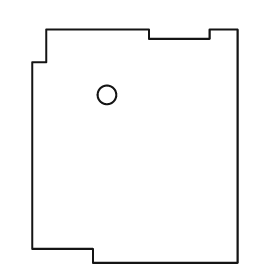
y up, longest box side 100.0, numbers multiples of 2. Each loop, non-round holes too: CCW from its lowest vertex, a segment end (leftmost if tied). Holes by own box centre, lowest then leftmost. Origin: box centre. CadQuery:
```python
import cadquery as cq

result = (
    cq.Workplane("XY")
    .moveTo(-18.0, -50.0)
    .lineTo(44.0, -50.0)
    .lineTo(44.0, 50.0)
    .lineTo(32.0, 50.0)
    .lineTo(32.0, 46.0)
    .lineTo(6.0, 46.0)
    .lineTo(6.0, 50.0)
    .lineTo(-38.0, 50.0)
    .lineTo(-38.0, 36.0)
    .lineTo(-44.0, 36.0)
    .lineTo(-44.0, -44.0)
    .lineTo(-18.0, -44.0)
    .close()
    .moveTo(-12.0, 22.0)
    .circle(4.0)
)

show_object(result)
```